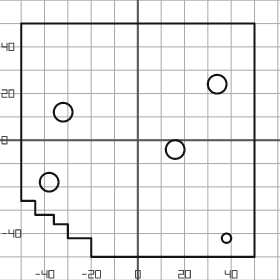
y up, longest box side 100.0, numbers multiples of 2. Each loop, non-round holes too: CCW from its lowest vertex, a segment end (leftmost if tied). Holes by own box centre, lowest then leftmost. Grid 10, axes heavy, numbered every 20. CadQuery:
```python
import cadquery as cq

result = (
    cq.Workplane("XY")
    .moveTo(-20.0, -50.0)
    .lineTo(50.0, -50.0)
    .lineTo(50.0, 50.0)
    .lineTo(-50.0, 50.0)
    .lineTo(-50.0, -26.0)
    .lineTo(-44.0, -26.0)
    .lineTo(-44.0, -32.0)
    .lineTo(-36.0, -32.0)
    .lineTo(-36.0, -36.0)
    .lineTo(-30.0, -36.0)
    .lineTo(-30.0, -42.0)
    .lineTo(-20.0, -42.0)
    .close()
    .moveTo(38.0, -42.0)
    .circle(2.0)
    .moveTo(-38.0, -18.0)
    .circle(4.0)
    .moveTo(16.0, -4.0)
    .circle(4.0)
    .moveTo(-32.0, 12.0)
    .circle(4.0)
    .moveTo(34.0, 24.0)
    .circle(4.0)
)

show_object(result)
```